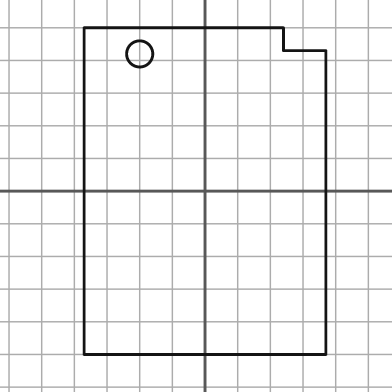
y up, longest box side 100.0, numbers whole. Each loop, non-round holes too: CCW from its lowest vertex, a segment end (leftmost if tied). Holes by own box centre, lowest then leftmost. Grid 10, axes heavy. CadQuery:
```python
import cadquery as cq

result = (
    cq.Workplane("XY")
    .moveTo(-37.0, -50.0)
    .lineTo(37.0, -50.0)
    .lineTo(37.0, 43.0)
    .lineTo(24.0, 43.0)
    .lineTo(24.0, 50.0)
    .lineTo(-37.0, 50.0)
    .close()
    .moveTo(-20.0, 42.0)
    .circle(4.0)
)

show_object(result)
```